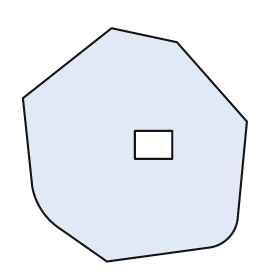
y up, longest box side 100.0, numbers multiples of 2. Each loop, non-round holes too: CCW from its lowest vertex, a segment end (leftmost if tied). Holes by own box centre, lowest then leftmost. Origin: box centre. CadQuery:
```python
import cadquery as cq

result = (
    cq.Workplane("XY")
    .moveTo(-12.0, -50.0)
    .lineTo(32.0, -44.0)
    .threePointArc((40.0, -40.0), (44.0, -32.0))
    .lineTo(48.0, 10.0)
    .lineTo(18.0, 44.0)
    .lineTo(-10.0, 50.0)
    .lineTo(-48.0, 20.0)
    .lineTo(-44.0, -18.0)
    .threePointArc((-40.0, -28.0), (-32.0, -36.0))
    .close()
    .moveTo(0.0, -6.0)
    .lineTo(16.0, -6.0)
    .lineTo(16.0, 6.0)
    .lineTo(0.0, 6.0)
    .close()
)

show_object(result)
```